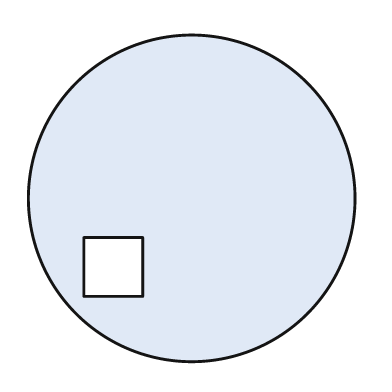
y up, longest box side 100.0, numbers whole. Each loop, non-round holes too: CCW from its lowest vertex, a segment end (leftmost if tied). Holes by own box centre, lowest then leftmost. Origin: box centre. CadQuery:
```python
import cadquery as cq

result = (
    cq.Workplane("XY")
    .moveTo(0.0, 0.0)
    .circle(50.0)
    .moveTo(-33.0, -30.0)
    .lineTo(-15.0, -30.0)
    .lineTo(-15.0, -12.0)
    .lineTo(-33.0, -12.0)
    .close()
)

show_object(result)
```